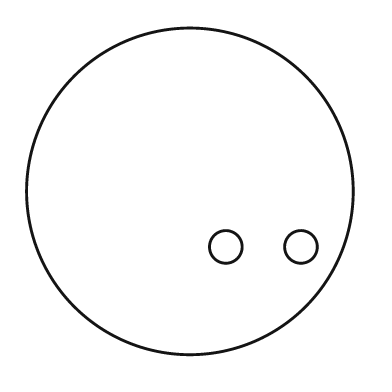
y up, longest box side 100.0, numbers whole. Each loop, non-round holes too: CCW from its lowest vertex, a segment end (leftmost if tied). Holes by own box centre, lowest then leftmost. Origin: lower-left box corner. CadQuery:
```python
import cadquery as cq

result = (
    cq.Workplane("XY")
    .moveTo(50.0, 50.0)
    .circle(50.0)
    .moveTo(61.0, 33.0)
    .circle(5.0)
    .moveTo(84.0, 33.0)
    .circle(5.0)
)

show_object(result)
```